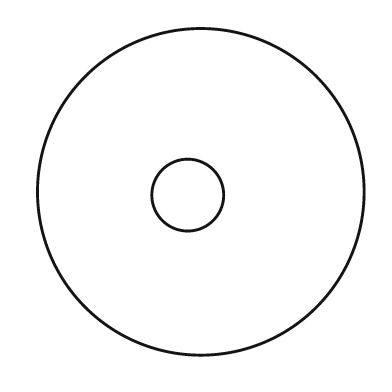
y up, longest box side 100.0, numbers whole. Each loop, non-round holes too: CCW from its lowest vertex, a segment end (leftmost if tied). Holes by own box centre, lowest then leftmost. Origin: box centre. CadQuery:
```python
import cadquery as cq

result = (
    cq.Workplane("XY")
    .moveTo(0.0, 0.0)
    .circle(50.0)
    .moveTo(-4.0, -1.0)
    .circle(11.0)
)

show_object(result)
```